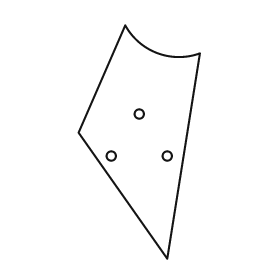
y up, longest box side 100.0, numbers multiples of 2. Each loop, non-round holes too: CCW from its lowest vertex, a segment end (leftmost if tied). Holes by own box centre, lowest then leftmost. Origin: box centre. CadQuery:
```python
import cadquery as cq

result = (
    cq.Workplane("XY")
    .moveTo(12.0, -50.0)
    .lineTo(26.0, 38.0)
    .threePointArc((8.0, 38.0), (-6.0, 50.0))
    .lineTo(-26.0, 4.0)
    .close()
    .moveTo(-12.0, -6.0)
    .circle(2.0)
    .moveTo(12.0, -6.0)
    .circle(2.0)
    .moveTo(0.0, 12.0)
    .circle(2.0)
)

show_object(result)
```